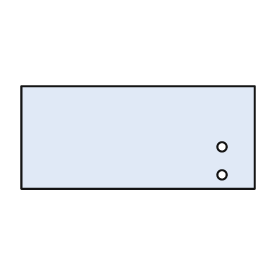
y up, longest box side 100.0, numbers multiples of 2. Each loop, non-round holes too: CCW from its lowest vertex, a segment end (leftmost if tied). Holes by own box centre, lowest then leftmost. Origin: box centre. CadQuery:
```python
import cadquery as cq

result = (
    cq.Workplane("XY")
    .moveTo(-50.0, -22.0)
    .lineTo(50.0, -22.0)
    .lineTo(50.0, 22.0)
    .lineTo(-50.0, 22.0)
    .close()
    .moveTo(36.0, -16.0)
    .circle(2.0)
    .moveTo(36.0, -4.0)
    .circle(2.0)
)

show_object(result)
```